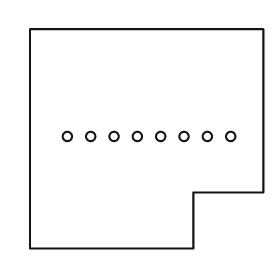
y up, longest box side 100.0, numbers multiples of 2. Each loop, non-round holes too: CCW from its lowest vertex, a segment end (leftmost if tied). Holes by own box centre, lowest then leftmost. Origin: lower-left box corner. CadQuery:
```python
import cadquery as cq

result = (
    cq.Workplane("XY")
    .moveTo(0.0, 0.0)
    .lineTo(70.0, 0.0)
    .lineTo(70.0, 24.0)
    .lineTo(100.0, 24.0)
    .lineTo(100.0, 94.0)
    .lineTo(0.0, 94.0)
    .close()
    .moveTo(16.0, 48.0)
    .circle(2.0)
    .moveTo(26.0, 48.0)
    .circle(2.0)
    .moveTo(36.0, 48.0)
    .circle(2.0)
    .moveTo(46.0, 48.0)
    .circle(2.0)
    .moveTo(56.0, 48.0)
    .circle(2.0)
    .moveTo(66.0, 48.0)
    .circle(2.0)
    .moveTo(76.0, 48.0)
    .circle(2.0)
    .moveTo(86.0, 48.0)
    .circle(2.0)
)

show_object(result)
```